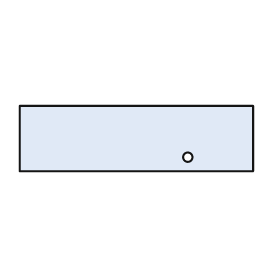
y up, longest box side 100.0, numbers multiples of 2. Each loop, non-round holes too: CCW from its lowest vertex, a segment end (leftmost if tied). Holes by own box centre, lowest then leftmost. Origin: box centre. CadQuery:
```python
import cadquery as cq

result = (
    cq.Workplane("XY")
    .moveTo(-50.0, -14.0)
    .lineTo(50.0, -14.0)
    .lineTo(50.0, 14.0)
    .lineTo(-50.0, 14.0)
    .close()
    .moveTo(22.0, -8.0)
    .circle(2.0)
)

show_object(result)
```